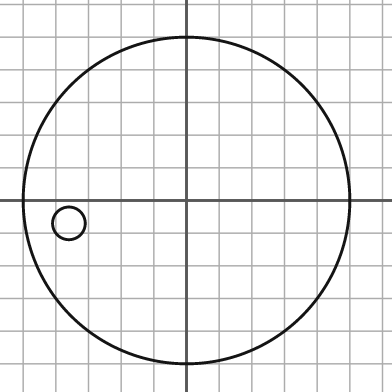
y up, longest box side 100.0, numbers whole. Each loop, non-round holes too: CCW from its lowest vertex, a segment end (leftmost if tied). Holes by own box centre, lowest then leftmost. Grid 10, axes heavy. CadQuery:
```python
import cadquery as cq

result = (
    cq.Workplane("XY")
    .moveTo(0.0, 0.0)
    .circle(50.0)
    .moveTo(-36.0, -7.0)
    .circle(5.0)
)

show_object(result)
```